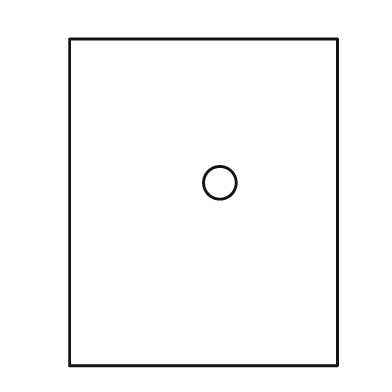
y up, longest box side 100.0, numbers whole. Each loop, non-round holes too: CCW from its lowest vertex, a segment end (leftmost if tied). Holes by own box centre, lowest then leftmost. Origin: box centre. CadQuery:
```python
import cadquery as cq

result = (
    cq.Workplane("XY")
    .moveTo(-41.0, -50.0)
    .lineTo(41.0, -50.0)
    .lineTo(41.0, 50.0)
    .lineTo(-41.0, 50.0)
    .close()
    .moveTo(5.0, 6.0)
    .circle(5.0)
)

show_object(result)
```